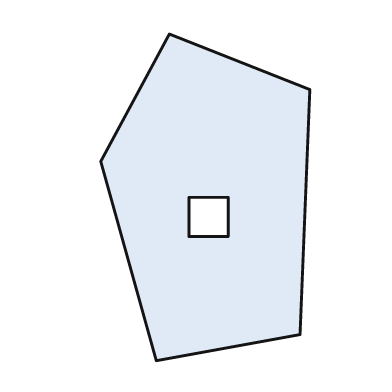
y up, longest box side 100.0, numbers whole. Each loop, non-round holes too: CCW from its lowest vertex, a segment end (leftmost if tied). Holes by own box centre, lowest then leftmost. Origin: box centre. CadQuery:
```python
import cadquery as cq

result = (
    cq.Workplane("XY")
    .moveTo(-15.0, -50.0)
    .lineTo(29.0, -42.0)
    .lineTo(32.0, 33.0)
    .lineTo(-11.0, 50.0)
    .lineTo(-32.0, 11.0)
    .close()
    .moveTo(-5.0, -12.0)
    .lineTo(7.0, -12.0)
    .lineTo(7.0, 0.0)
    .lineTo(-5.0, 0.0)
    .close()
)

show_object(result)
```